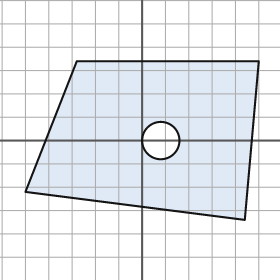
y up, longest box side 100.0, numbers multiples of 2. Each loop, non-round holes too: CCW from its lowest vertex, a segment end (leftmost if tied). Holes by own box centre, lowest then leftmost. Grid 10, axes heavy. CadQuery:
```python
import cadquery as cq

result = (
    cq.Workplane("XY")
    .moveTo(44.0, -34.0)
    .lineTo(50.0, 34.0)
    .lineTo(-28.0, 34.0)
    .lineTo(-50.0, -22.0)
    .close()
    .moveTo(8.0, 0.0)
    .circle(8.0)
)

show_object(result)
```